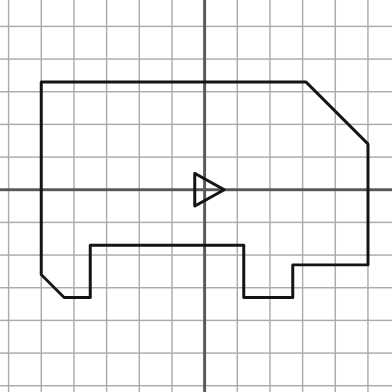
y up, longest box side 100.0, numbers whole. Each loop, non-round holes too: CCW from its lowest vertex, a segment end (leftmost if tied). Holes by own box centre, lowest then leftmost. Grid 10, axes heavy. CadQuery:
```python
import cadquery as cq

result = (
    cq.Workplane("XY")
    .moveTo(-43.0, -33.0)
    .lineTo(-35.0, -33.0)
    .lineTo(-35.0, -17.0)
    .lineTo(12.0, -17.0)
    .lineTo(12.0, -33.0)
    .lineTo(27.0, -33.0)
    .lineTo(27.0, -23.0)
    .lineTo(50.0, -23.0)
    .lineTo(50.0, 14.0)
    .lineTo(31.0, 33.0)
    .lineTo(-50.0, 33.0)
    .lineTo(-50.0, -26.0)
    .close()
    .moveTo(-3.0, -5.0)
    .lineTo(6.0, 0.0)
    .lineTo(-3.0, 5.0)
    .close()
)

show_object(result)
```